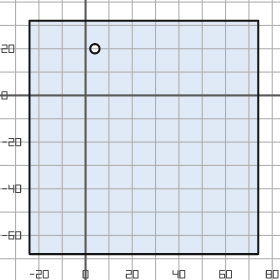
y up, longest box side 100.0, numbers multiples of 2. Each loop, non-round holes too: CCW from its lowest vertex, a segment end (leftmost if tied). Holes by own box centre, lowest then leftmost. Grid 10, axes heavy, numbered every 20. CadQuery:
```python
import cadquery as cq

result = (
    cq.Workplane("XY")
    .moveTo(-24.0, -68.0)
    .lineTo(74.0, -68.0)
    .lineTo(74.0, 32.0)
    .lineTo(-24.0, 32.0)
    .close()
    .moveTo(4.0, 20.0)
    .circle(2.0)
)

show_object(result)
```